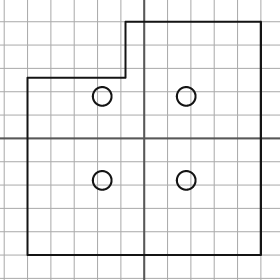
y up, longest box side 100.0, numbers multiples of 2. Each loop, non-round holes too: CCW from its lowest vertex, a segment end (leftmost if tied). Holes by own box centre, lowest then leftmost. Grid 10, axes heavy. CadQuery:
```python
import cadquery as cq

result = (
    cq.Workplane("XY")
    .moveTo(-50.0, -50.0)
    .lineTo(50.0, -50.0)
    .lineTo(50.0, 50.0)
    .lineTo(-8.0, 50.0)
    .lineTo(-8.0, 26.0)
    .lineTo(-50.0, 26.0)
    .close()
    .moveTo(-18.0, -18.0)
    .circle(4.0)
    .moveTo(18.0, -18.0)
    .circle(4.0)
    .moveTo(-18.0, 18.0)
    .circle(4.0)
    .moveTo(18.0, 18.0)
    .circle(4.0)
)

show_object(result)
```